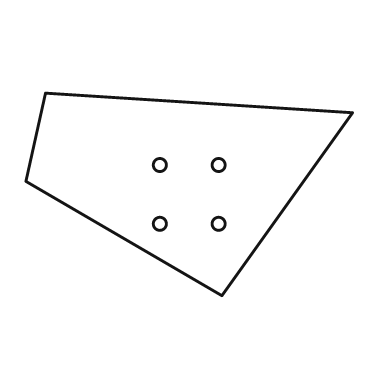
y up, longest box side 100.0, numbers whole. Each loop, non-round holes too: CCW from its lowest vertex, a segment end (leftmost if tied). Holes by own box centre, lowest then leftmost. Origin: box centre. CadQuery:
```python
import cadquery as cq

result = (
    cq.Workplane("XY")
    .moveTo(10.0, -31.0)
    .lineTo(50.0, 25.0)
    .lineTo(-44.0, 31.0)
    .lineTo(-50.0, 4.0)
    .close()
    .moveTo(-9.0, -9.0)
    .circle(2.0)
    .moveTo(9.0, -9.0)
    .circle(2.0)
    .moveTo(-9.0, 9.0)
    .circle(2.0)
    .moveTo(9.0, 9.0)
    .circle(2.0)
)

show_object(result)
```